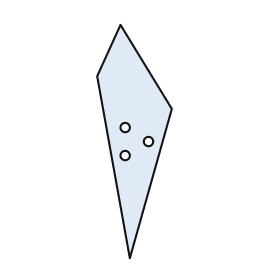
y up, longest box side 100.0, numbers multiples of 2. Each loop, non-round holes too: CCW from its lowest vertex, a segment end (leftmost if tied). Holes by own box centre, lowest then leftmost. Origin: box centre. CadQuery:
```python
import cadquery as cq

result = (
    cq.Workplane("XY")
    .moveTo(-2.0, -50.0)
    .lineTo(16.0, 14.0)
    .lineTo(-6.0, 50.0)
    .lineTo(-16.0, 28.0)
    .close()
    .moveTo(-4.0, -6.0)
    .circle(2.0)
    .moveTo(6.0, 0.0)
    .circle(2.0)
    .moveTo(-4.0, 6.0)
    .circle(2.0)
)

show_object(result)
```